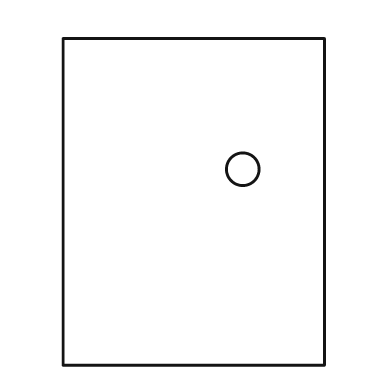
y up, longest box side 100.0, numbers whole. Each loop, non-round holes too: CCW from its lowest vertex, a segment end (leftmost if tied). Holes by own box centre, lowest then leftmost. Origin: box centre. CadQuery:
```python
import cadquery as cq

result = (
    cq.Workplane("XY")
    .moveTo(-40.0, -50.0)
    .lineTo(40.0, -50.0)
    .lineTo(40.0, 50.0)
    .lineTo(-40.0, 50.0)
    .close()
    .moveTo(15.0, 10.0)
    .circle(5.0)
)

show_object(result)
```